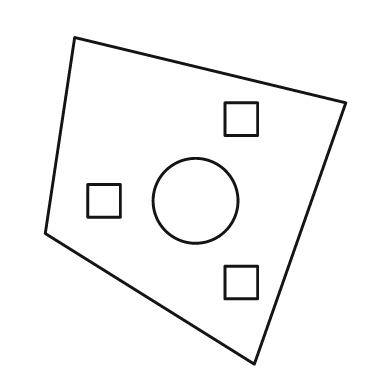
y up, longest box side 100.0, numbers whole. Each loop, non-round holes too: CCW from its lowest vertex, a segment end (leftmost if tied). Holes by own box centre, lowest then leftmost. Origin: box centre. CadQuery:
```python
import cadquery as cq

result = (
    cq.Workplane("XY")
    .moveTo(18.0, -50.0)
    .lineTo(46.0, 30.0)
    .lineTo(-37.0, 50.0)
    .lineTo(-46.0, -10.0)
    .close()
    .moveTo(9.0, -30.0)
    .lineTo(19.0, -30.0)
    .lineTo(19.0, -20.0)
    .lineTo(9.0, -20.0)
    .close()
    .moveTo(-33.0, -5.0)
    .lineTo(-23.0, -5.0)
    .lineTo(-23.0, 5.0)
    .lineTo(-33.0, 5.0)
    .close()
    .moveTo(0.0, 0.0)
    .circle(13.0)
    .moveTo(9.0, 20.0)
    .lineTo(19.0, 20.0)
    .lineTo(19.0, 30.0)
    .lineTo(9.0, 30.0)
    .close()
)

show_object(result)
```